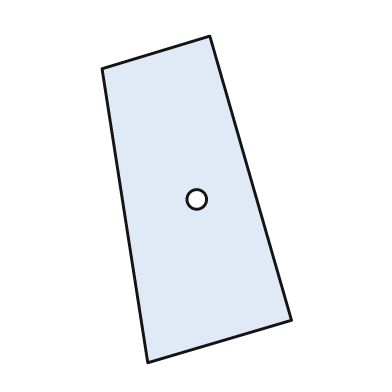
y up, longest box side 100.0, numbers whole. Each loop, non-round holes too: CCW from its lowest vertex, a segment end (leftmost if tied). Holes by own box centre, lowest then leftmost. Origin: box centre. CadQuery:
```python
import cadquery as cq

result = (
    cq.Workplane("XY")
    .moveTo(-15.0, -50.0)
    .lineTo(29.0, -37.0)
    .lineTo(4.0, 50.0)
    .lineTo(-29.0, 40.0)
    .close()
    .moveTo(0.0, 0.0)
    .circle(3.0)
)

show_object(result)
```